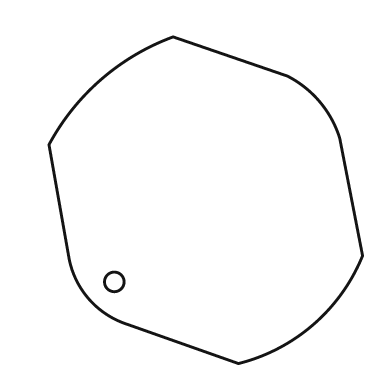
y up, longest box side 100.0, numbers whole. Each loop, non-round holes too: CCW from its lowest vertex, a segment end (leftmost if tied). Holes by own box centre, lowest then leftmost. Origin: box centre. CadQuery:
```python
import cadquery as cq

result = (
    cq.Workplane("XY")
    .moveTo(10.0, -50.0)
    .threePointArc((33.0, -38.0), (48.0, -17.0))
    .lineTo(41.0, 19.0)
    .threePointArc((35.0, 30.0), (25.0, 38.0))
    .lineTo(-10.0, 50.0)
    .threePointArc((-32.0, 37.0), (-48.0, 17.0))
    .lineTo(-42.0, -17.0)
    .threePointArc((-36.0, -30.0), (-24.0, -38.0))
    .close()
    .moveTo(-28.0, -25.0)
    .circle(3.0)
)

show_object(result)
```